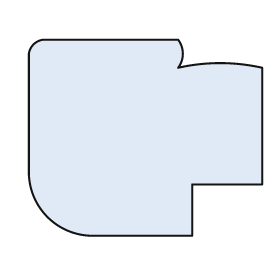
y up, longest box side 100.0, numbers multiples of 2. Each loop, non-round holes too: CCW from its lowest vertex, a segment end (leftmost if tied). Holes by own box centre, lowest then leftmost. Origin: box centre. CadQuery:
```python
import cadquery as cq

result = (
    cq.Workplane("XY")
    .moveTo(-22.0, -42.0)
    .lineTo(20.0, -42.0)
    .lineTo(20.0, -20.0)
    .lineTo(50.0, -20.0)
    .lineTo(50.0, 30.0)
    .threePointArc((32.0, 32.0), (14.0, 30.0))
    .threePointArc((16.0, 36.0), (14.0, 42.0))
    .lineTo(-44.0, 42.0)
    .threePointArc((-48.0, 40.0), (-50.0, 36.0))
    .lineTo(-50.0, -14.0)
    .threePointArc((-42.0, -34.0), (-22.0, -42.0))
    .close()
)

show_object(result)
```